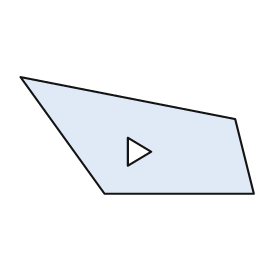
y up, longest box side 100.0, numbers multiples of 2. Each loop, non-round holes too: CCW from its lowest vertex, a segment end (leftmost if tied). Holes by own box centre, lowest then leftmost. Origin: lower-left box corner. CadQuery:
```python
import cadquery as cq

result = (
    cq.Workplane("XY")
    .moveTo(36.0, 0.0)
    .lineTo(100.0, 0.0)
    .lineTo(92.0, 32.0)
    .lineTo(0.0, 50.0)
    .close()
    .moveTo(46.0, 12.0)
    .lineTo(56.0, 18.0)
    .lineTo(46.0, 24.0)
    .close()
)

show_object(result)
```